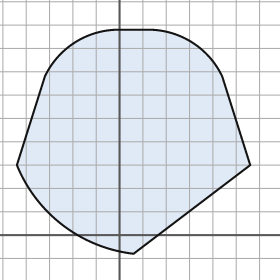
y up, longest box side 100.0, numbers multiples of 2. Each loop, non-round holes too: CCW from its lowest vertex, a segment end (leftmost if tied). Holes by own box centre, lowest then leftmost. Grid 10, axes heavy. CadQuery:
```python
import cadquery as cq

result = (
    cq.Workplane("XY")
    .moveTo(6.0, -8.0)
    .lineTo(56.0, 30.0)
    .lineTo(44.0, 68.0)
    .threePointArc((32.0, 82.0), (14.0, 88.0))
    .lineTo(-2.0, 88.0)
    .threePointArc((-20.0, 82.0), (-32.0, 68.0))
    .lineTo(-44.0, 30.0)
    .threePointArc((-24.0, 4.0), (6.0, -8.0))
    .close()
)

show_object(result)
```